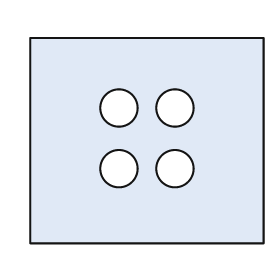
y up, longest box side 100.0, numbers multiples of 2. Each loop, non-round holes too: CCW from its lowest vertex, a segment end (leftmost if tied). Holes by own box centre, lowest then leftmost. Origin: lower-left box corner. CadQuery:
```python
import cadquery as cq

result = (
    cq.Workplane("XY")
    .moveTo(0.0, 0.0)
    .lineTo(100.0, 0.0)
    .lineTo(100.0, 88.0)
    .lineTo(0.0, 88.0)
    .close()
    .moveTo(38.0, 32.0)
    .circle(8.0)
    .moveTo(62.0, 32.0)
    .circle(8.0)
    .moveTo(38.0, 58.0)
    .circle(8.0)
    .moveTo(62.0, 58.0)
    .circle(8.0)
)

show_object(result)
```